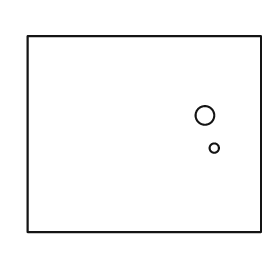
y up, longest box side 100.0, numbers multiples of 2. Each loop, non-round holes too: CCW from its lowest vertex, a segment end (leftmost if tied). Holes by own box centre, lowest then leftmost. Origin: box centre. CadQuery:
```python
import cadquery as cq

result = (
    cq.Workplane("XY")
    .moveTo(-50.0, -42.0)
    .lineTo(50.0, -42.0)
    .lineTo(50.0, 42.0)
    .lineTo(-50.0, 42.0)
    .close()
    .moveTo(30.0, -6.0)
    .circle(2.0)
    .moveTo(26.0, 8.0)
    .circle(4.0)
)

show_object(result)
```